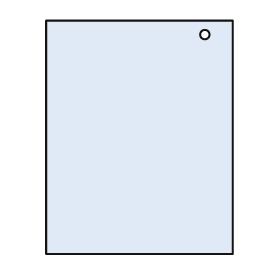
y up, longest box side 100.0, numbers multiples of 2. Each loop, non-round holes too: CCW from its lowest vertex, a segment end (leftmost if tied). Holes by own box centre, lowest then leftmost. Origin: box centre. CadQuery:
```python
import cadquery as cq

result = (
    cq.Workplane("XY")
    .moveTo(-40.0, -50.0)
    .lineTo(40.0, -50.0)
    .lineTo(40.0, 50.0)
    .lineTo(-40.0, 50.0)
    .close()
    .moveTo(28.0, 44.0)
    .circle(2.0)
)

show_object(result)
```